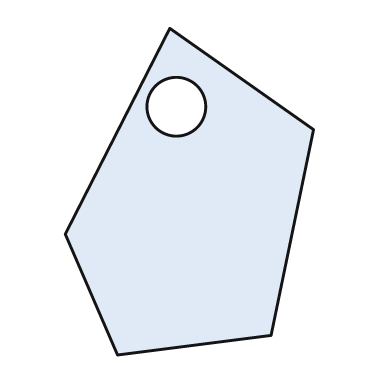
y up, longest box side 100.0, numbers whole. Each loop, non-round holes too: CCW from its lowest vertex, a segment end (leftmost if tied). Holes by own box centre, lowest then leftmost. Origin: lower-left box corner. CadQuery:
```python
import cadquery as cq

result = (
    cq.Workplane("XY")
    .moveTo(16.0, 0.0)
    .lineTo(63.0, 6.0)
    .lineTo(76.0, 69.0)
    .lineTo(32.0, 100.0)
    .lineTo(0.0, 37.0)
    .close()
    .moveTo(34.0, 76.0)
    .circle(9.0)
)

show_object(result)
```